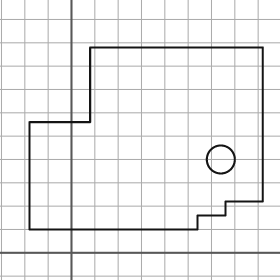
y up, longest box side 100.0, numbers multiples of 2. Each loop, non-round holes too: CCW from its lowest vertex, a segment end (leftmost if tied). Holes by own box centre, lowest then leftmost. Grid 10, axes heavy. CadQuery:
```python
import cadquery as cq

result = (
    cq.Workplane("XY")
    .moveTo(-18.0, 10.0)
    .lineTo(54.0, 10.0)
    .lineTo(54.0, 16.0)
    .lineTo(66.0, 16.0)
    .lineTo(66.0, 22.0)
    .lineTo(82.0, 22.0)
    .lineTo(82.0, 88.0)
    .lineTo(8.0, 88.0)
    .lineTo(8.0, 56.0)
    .lineTo(-18.0, 56.0)
    .close()
    .moveTo(64.0, 40.0)
    .circle(6.0)
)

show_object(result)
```